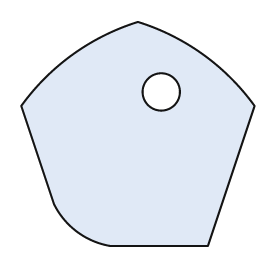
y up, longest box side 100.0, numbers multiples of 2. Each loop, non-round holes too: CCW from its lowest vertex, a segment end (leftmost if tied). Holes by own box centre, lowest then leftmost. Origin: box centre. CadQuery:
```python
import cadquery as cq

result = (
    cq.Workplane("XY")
    .moveTo(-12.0, -48.0)
    .lineTo(30.0, -48.0)
    .lineTo(50.0, 12.0)
    .threePointArc((28.0, 34.0), (0.0, 48.0))
    .threePointArc((-28.0, 34.0), (-50.0, 12.0))
    .lineTo(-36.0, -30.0)
    .threePointArc((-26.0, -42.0), (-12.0, -48.0))
    .close()
    .moveTo(10.0, 18.0)
    .circle(8.0)
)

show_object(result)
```